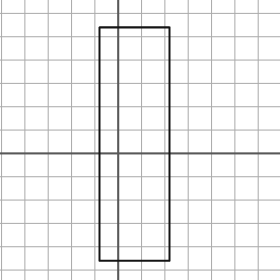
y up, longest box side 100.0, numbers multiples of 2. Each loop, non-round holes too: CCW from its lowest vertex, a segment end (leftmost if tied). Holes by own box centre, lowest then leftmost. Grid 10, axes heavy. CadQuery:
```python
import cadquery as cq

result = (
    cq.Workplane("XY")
    .moveTo(-8.0, -46.0)
    .lineTo(22.0, -46.0)
    .lineTo(22.0, 54.0)
    .lineTo(-8.0, 54.0)
    .close()
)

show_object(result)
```